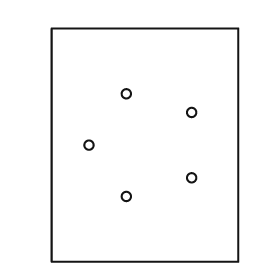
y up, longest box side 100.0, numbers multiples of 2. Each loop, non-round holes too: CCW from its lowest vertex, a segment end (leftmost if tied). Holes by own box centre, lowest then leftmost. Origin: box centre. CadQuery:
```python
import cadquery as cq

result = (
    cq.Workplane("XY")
    .moveTo(-40.0, -50.0)
    .lineTo(40.0, -50.0)
    .lineTo(40.0, 50.0)
    .lineTo(-40.0, 50.0)
    .close()
    .moveTo(-8.0, -22.0)
    .circle(2.0)
    .moveTo(20.0, -14.0)
    .circle(2.0)
    .moveTo(-24.0, 0.0)
    .circle(2.0)
    .moveTo(20.0, 14.0)
    .circle(2.0)
    .moveTo(-8.0, 22.0)
    .circle(2.0)
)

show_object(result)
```